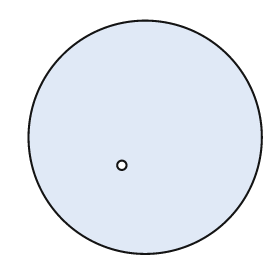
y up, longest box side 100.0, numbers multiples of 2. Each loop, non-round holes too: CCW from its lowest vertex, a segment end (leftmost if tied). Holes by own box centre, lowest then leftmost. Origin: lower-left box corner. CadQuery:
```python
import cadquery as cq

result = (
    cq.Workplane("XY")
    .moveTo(50.0, 50.0)
    .circle(50.0)
    .moveTo(40.0, 38.0)
    .circle(2.0)
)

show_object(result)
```